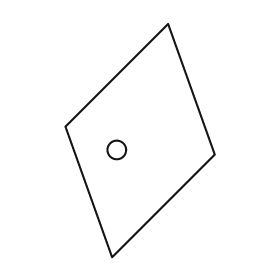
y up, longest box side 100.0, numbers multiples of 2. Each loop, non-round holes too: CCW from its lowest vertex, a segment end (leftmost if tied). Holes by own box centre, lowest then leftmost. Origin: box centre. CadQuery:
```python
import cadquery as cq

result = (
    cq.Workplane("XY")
    .moveTo(-12.0, -50.0)
    .lineTo(32.0, -6.0)
    .lineTo(12.0, 50.0)
    .lineTo(-32.0, 6.0)
    .close()
    .moveTo(-10.0, -4.0)
    .circle(4.0)
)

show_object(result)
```